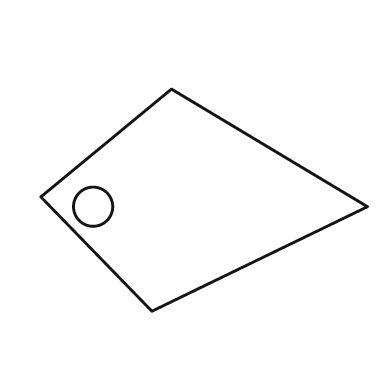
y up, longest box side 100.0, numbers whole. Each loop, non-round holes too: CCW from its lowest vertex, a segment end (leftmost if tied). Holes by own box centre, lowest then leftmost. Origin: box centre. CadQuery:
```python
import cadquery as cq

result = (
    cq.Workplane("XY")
    .moveTo(-16.0, -34.0)
    .lineTo(50.0, -2.0)
    .lineTo(-10.0, 34.0)
    .lineTo(-50.0, 1.0)
    .close()
    .moveTo(-34.0, -2.0)
    .circle(6.0)
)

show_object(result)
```